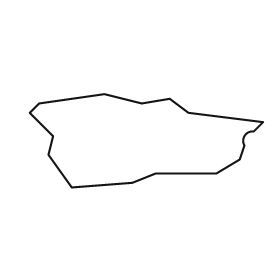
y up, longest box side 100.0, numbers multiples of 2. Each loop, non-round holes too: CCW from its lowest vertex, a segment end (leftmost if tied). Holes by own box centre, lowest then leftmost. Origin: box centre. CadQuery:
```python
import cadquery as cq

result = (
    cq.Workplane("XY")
    .moveTo(-32.0, -20.0)
    .lineTo(-6.0, -18.0)
    .lineTo(4.0, -14.0)
    .lineTo(30.0, -14.0)
    .lineTo(40.0, -8.0)
    .lineTo(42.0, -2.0)
    .threePointArc((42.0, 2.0), (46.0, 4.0))
    .lineTo(50.0, 8.0)
    .lineTo(18.0, 12.0)
    .lineTo(10.0, 18.0)
    .lineTo(-2.0, 16.0)
    .lineTo(-18.0, 20.0)
    .lineTo(-46.0, 16.0)
    .lineTo(-50.0, 12.0)
    .lineTo(-40.0, 2.0)
    .lineTo(-42.0, -6.0)
    .close()
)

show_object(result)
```